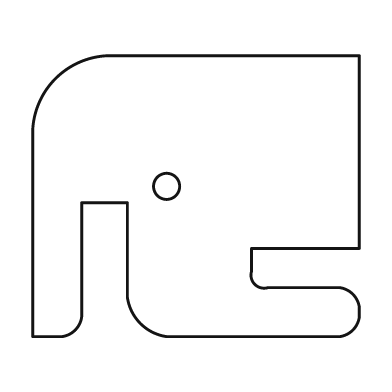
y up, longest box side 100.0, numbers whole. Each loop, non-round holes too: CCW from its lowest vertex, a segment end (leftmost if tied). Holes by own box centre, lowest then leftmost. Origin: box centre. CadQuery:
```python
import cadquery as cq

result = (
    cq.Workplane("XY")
    .moveTo(-50.0, -43.0)
    .lineTo(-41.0, -43.0)
    .threePointArc((-37.0, -41.0), (-35.0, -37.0))
    .lineTo(-35.0, -2.0)
    .lineTo(-21.0, -2.0)
    .lineTo(-21.0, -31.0)
    .threePointArc((-17.0, -39.0), (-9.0, -43.0))
    .lineTo(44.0, -43.0)
    .threePointArc((48.0, -41.0), (50.0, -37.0))
    .lineTo(50.0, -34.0)
    .threePointArc((48.0, -30.0), (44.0, -28.0))
    .lineTo(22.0, -28.0)
    .threePointArc((18.0, -27.0), (17.0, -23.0))
    .lineTo(17.0, -16.0)
    .lineTo(50.0, -16.0)
    .lineTo(50.0, 43.0)
    .lineTo(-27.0, 43.0)
    .threePointArc((-43.0, 36.0), (-50.0, 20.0))
    .close()
    .moveTo(-9.0, 3.0)
    .circle(4.0)
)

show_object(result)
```